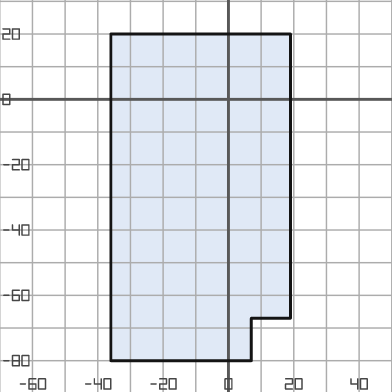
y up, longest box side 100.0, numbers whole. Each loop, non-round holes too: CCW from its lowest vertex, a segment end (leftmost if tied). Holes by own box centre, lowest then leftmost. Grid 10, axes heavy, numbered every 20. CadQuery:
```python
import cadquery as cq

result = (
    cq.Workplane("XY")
    .moveTo(-36.0, -80.0)
    .lineTo(7.0, -80.0)
    .lineTo(7.0, -67.0)
    .lineTo(19.0, -67.0)
    .lineTo(19.0, 20.0)
    .lineTo(-36.0, 20.0)
    .close()
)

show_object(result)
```